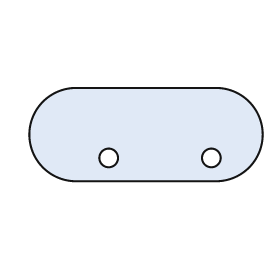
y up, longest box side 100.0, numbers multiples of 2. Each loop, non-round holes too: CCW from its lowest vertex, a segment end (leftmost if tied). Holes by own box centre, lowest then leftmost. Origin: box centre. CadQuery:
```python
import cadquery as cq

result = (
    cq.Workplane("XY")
    .moveTo(-30.0, -20.0)
    .lineTo(30.0, -20.0)
    .threePointArc((50.0, 0.0), (30.0, 20.0))
    .lineTo(-30.0, 20.0)
    .threePointArc((-50.0, 0.0), (-30.0, -20.0))
    .close()
    .moveTo(-16.0, -10.0)
    .circle(4.0)
    .moveTo(28.0, -10.0)
    .circle(4.0)
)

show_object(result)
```